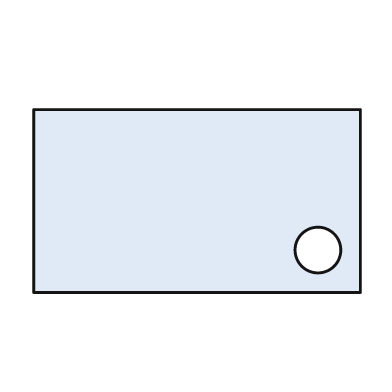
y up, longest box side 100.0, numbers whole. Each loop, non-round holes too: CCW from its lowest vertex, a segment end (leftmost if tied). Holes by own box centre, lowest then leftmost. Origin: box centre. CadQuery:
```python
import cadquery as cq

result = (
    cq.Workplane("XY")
    .moveTo(-50.0, -28.0)
    .lineTo(50.0, -28.0)
    .lineTo(50.0, 28.0)
    .lineTo(-50.0, 28.0)
    .close()
    .moveTo(37.0, -15.0)
    .circle(7.0)
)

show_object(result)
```